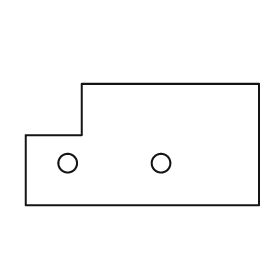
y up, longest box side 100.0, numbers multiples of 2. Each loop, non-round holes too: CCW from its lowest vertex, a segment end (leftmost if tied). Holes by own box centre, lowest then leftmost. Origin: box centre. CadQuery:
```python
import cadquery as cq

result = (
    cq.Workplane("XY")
    .moveTo(-50.0, -26.0)
    .lineTo(50.0, -26.0)
    .lineTo(50.0, 26.0)
    .lineTo(-26.0, 26.0)
    .lineTo(-26.0, 4.0)
    .lineTo(-50.0, 4.0)
    .close()
    .moveTo(-32.0, -8.0)
    .circle(4.0)
    .moveTo(8.0, -8.0)
    .circle(4.0)
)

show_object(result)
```